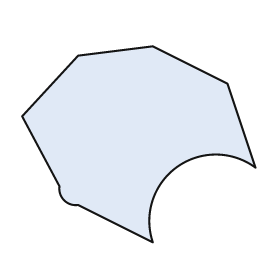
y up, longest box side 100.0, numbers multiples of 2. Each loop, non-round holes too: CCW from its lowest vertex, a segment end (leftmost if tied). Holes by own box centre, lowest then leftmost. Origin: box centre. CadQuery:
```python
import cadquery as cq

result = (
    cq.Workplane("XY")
    .moveTo(6.0, -42.0)
    .threePointArc((16.0, -10.0), (50.0, -10.0))
    .lineTo(38.0, 26.0)
    .lineTo(6.0, 42.0)
    .lineTo(-26.0, 38.0)
    .lineTo(-50.0, 12.0)
    .lineTo(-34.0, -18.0)
    .threePointArc((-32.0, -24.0), (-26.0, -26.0))
    .close()
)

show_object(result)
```